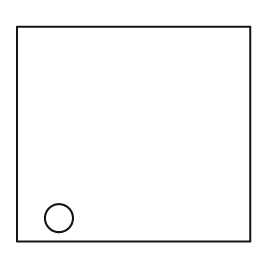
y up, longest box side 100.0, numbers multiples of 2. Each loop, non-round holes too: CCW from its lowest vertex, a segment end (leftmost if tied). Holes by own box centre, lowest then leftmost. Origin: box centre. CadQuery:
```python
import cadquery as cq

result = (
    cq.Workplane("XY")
    .moveTo(-50.0, -46.0)
    .lineTo(50.0, -46.0)
    .lineTo(50.0, 46.0)
    .lineTo(-50.0, 46.0)
    .close()
    .moveTo(-32.0, -36.0)
    .circle(6.0)
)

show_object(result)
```